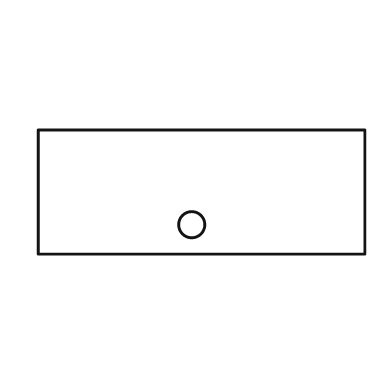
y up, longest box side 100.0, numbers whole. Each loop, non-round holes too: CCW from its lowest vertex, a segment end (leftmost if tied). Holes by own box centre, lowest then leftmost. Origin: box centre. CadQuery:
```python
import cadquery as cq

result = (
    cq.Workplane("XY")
    .moveTo(-50.0, -19.0)
    .lineTo(50.0, -19.0)
    .lineTo(50.0, 19.0)
    .lineTo(-50.0, 19.0)
    .close()
    .moveTo(-3.0, -10.0)
    .circle(4.0)
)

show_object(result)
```